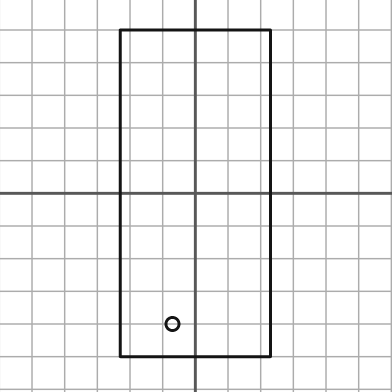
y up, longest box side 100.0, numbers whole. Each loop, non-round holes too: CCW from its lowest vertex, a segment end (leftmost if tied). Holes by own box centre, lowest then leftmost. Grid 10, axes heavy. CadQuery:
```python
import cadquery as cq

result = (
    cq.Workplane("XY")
    .moveTo(-23.0, -50.0)
    .lineTo(23.0, -50.0)
    .lineTo(23.0, 50.0)
    .lineTo(-23.0, 50.0)
    .close()
    .moveTo(-7.0, -40.0)
    .circle(2.0)
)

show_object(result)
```